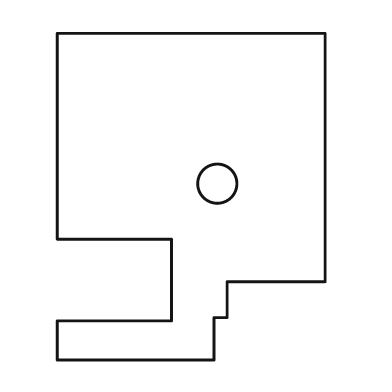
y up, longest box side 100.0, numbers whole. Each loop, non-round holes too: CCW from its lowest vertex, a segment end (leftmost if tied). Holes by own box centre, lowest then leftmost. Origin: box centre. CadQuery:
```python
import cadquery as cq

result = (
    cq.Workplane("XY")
    .moveTo(-41.0, -50.0)
    .lineTo(7.0, -50.0)
    .lineTo(7.0, -37.0)
    .lineTo(11.0, -37.0)
    .lineTo(11.0, -26.0)
    .lineTo(41.0, -26.0)
    .lineTo(41.0, 50.0)
    .lineTo(-41.0, 50.0)
    .lineTo(-41.0, -13.0)
    .lineTo(-6.0, -13.0)
    .lineTo(-6.0, -38.0)
    .lineTo(-41.0, -38.0)
    .close()
    .moveTo(8.0, 4.0)
    .circle(6.0)
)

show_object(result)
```